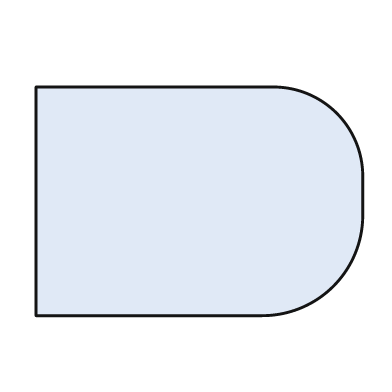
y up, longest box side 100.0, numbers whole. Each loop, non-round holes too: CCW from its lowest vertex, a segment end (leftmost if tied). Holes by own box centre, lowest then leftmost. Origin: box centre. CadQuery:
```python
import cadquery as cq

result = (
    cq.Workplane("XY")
    .moveTo(-50.0, -35.0)
    .lineTo(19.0, -35.0)
    .threePointArc((41.0, -26.0), (50.0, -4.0))
    .lineTo(50.0, 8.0)
    .threePointArc((42.0, 27.0), (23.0, 35.0))
    .lineTo(-50.0, 35.0)
    .close()
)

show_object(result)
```